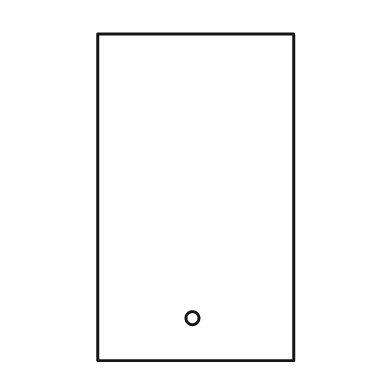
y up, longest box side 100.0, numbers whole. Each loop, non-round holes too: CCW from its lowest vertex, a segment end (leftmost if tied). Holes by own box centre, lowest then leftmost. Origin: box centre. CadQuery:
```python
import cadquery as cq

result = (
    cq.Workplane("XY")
    .moveTo(-30.0, -50.0)
    .lineTo(30.0, -50.0)
    .lineTo(30.0, 50.0)
    .lineTo(-30.0, 50.0)
    .close()
    .moveTo(-1.0, -37.0)
    .circle(2.0)
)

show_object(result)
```